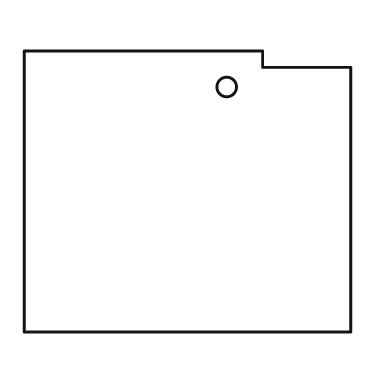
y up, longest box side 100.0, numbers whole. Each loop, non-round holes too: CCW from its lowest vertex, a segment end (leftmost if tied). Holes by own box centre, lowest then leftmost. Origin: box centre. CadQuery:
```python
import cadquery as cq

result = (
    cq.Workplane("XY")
    .moveTo(-50.0, -43.0)
    .lineTo(50.0, -43.0)
    .lineTo(50.0, 38.0)
    .lineTo(23.0, 38.0)
    .lineTo(23.0, 43.0)
    .lineTo(-50.0, 43.0)
    .close()
    .moveTo(12.0, 32.0)
    .circle(3.0)
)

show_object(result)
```